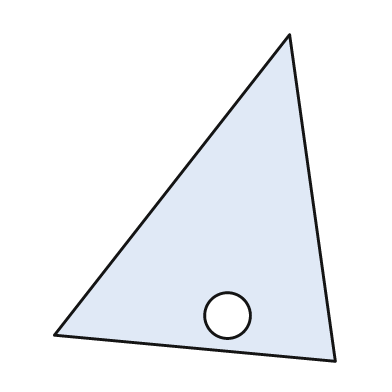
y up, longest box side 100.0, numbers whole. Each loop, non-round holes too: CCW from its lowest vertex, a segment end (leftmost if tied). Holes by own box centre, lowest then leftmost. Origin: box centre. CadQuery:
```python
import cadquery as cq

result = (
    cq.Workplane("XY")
    .moveTo(43.0, -50.0)
    .lineTo(29.0, 50.0)
    .lineTo(-43.0, -42.0)
    .close()
    .moveTo(10.0, -36.0)
    .circle(7.0)
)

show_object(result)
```